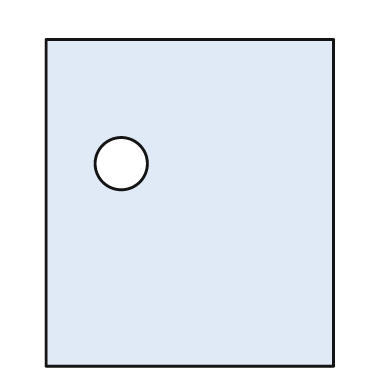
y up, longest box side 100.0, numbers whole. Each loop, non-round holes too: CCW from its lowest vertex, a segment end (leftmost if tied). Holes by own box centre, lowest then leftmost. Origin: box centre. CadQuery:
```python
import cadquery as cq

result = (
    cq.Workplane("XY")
    .moveTo(-44.0, -50.0)
    .lineTo(44.0, -50.0)
    .lineTo(44.0, 50.0)
    .lineTo(-44.0, 50.0)
    .close()
    .moveTo(-21.0, 12.0)
    .circle(8.0)
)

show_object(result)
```